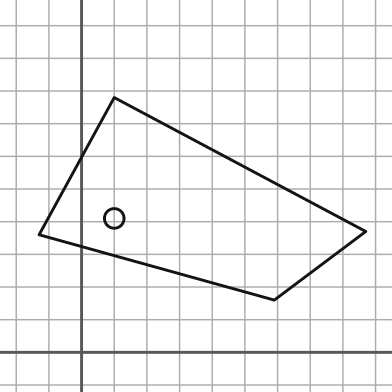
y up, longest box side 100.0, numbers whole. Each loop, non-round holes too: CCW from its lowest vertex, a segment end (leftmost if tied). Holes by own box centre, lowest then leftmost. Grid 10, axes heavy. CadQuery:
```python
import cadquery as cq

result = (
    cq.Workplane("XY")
    .moveTo(59.0, 16.0)
    .lineTo(87.0, 37.0)
    .lineTo(10.0, 78.0)
    .lineTo(-13.0, 36.0)
    .close()
    .moveTo(10.0, 41.0)
    .circle(3.0)
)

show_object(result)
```